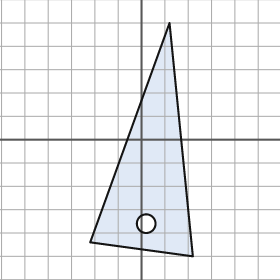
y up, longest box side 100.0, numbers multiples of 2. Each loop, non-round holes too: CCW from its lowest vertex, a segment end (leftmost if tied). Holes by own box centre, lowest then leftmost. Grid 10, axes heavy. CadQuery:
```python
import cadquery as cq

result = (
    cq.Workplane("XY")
    .moveTo(22.0, -50.0)
    .lineTo(12.0, 50.0)
    .lineTo(-22.0, -44.0)
    .close()
    .moveTo(2.0, -36.0)
    .circle(4.0)
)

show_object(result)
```